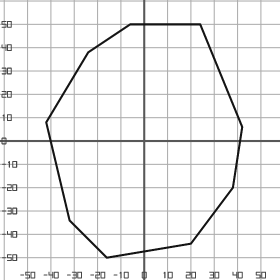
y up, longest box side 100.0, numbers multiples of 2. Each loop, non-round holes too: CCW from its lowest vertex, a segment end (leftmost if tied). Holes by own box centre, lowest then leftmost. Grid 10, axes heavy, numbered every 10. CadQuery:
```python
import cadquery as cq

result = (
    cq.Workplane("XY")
    .moveTo(-16.0, -50.0)
    .lineTo(20.0, -44.0)
    .lineTo(38.0, -20.0)
    .lineTo(42.0, 6.0)
    .lineTo(24.0, 50.0)
    .lineTo(-6.0, 50.0)
    .lineTo(-24.0, 38.0)
    .lineTo(-42.0, 8.0)
    .lineTo(-32.0, -34.0)
    .close()
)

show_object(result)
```